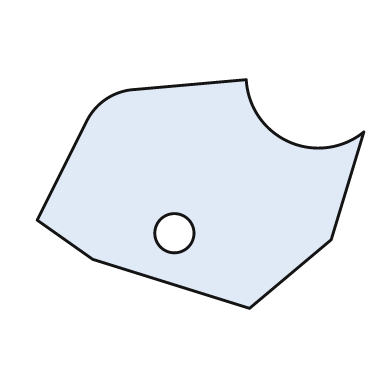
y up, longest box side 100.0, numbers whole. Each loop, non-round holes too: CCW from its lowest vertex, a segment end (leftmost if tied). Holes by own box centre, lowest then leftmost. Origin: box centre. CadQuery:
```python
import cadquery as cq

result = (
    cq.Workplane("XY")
    .moveTo(15.0, -35.0)
    .lineTo(40.0, -14.0)
    .lineTo(50.0, 19.0)
    .threePointArc((27.0, 16.0), (14.0, 35.0))
    .lineTo(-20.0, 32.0)
    .threePointArc((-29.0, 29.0), (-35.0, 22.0))
    .lineTo(-50.0, -8.0)
    .lineTo(-33.0, -20.0)
    .close()
    .moveTo(-8.0, -12.0)
    .circle(6.0)
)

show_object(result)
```